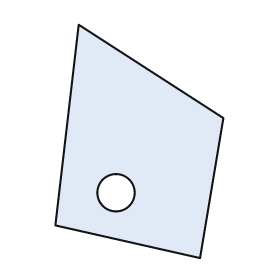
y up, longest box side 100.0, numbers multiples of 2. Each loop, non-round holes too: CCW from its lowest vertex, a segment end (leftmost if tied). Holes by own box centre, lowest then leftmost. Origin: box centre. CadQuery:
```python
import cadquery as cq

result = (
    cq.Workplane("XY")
    .moveTo(26.0, -50.0)
    .lineTo(36.0, 10.0)
    .lineTo(-26.0, 50.0)
    .lineTo(-36.0, -36.0)
    .close()
    .moveTo(-10.0, -22.0)
    .circle(8.0)
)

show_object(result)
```